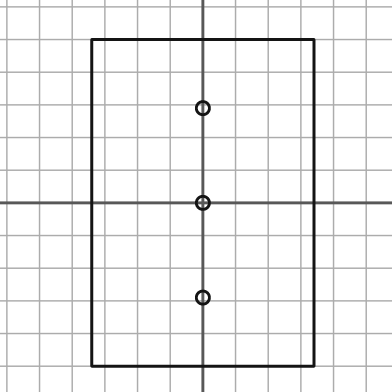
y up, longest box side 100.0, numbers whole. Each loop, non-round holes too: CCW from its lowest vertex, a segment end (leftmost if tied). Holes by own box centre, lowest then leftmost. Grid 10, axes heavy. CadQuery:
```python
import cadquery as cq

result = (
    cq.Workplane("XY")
    .moveTo(-34.0, -50.0)
    .lineTo(34.0, -50.0)
    .lineTo(34.0, 50.0)
    .lineTo(-34.0, 50.0)
    .close()
    .moveTo(0.0, -29.0)
    .circle(2.0)
    .moveTo(0.0, 0.0)
    .circle(2.0)
    .moveTo(0.0, 29.0)
    .circle(2.0)
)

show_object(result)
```